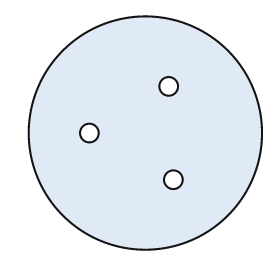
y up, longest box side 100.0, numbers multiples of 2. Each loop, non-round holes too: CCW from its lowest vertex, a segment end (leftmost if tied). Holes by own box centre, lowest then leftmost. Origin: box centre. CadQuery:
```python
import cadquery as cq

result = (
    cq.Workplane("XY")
    .moveTo(0.0, 0.0)
    .circle(50.0)
    .moveTo(12.0, -20.0)
    .circle(4.0)
    .moveTo(-24.0, 0.0)
    .circle(4.0)
    .moveTo(10.0, 20.0)
    .circle(4.0)
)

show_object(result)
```